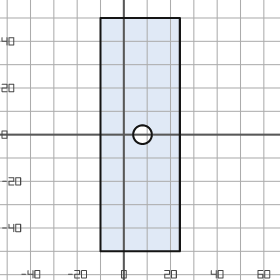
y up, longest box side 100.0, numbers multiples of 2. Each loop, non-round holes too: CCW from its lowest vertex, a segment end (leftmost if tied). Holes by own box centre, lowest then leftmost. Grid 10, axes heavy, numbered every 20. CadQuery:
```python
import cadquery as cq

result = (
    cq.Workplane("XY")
    .moveTo(-10.0, -50.0)
    .lineTo(24.0, -50.0)
    .lineTo(24.0, 50.0)
    .lineTo(-10.0, 50.0)
    .close()
    .moveTo(8.0, 0.0)
    .circle(4.0)
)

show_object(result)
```